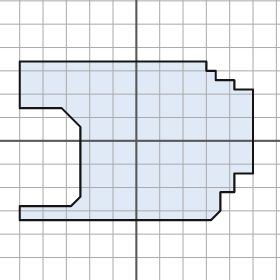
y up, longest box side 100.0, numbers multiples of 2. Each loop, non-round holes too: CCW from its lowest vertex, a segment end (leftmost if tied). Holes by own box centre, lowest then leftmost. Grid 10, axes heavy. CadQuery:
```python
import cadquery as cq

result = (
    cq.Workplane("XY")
    .moveTo(-50.0, -34.0)
    .lineTo(32.0, -34.0)
    .lineTo(36.0, -30.0)
    .lineTo(36.0, -22.0)
    .lineTo(42.0, -22.0)
    .lineTo(42.0, -14.0)
    .lineTo(50.0, -14.0)
    .lineTo(50.0, 22.0)
    .lineTo(42.0, 22.0)
    .lineTo(42.0, 26.0)
    .lineTo(34.0, 26.0)
    .lineTo(34.0, 30.0)
    .lineTo(30.0, 30.0)
    .lineTo(30.0, 34.0)
    .lineTo(-50.0, 34.0)
    .lineTo(-50.0, 14.0)
    .lineTo(-32.0, 14.0)
    .lineTo(-24.0, 6.0)
    .lineTo(-24.0, -24.0)
    .lineTo(-28.0, -28.0)
    .lineTo(-50.0, -28.0)
    .close()
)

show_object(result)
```